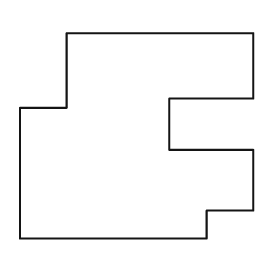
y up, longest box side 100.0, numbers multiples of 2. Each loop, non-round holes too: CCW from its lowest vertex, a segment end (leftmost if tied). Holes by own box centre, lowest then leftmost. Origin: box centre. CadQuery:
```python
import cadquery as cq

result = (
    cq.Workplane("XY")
    .moveTo(-50.0, -44.0)
    .lineTo(30.0, -44.0)
    .lineTo(30.0, -32.0)
    .lineTo(50.0, -32.0)
    .lineTo(50.0, -6.0)
    .lineTo(14.0, -6.0)
    .lineTo(14.0, 16.0)
    .lineTo(50.0, 16.0)
    .lineTo(50.0, 44.0)
    .lineTo(-30.0, 44.0)
    .lineTo(-30.0, 12.0)
    .lineTo(-50.0, 12.0)
    .close()
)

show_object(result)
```